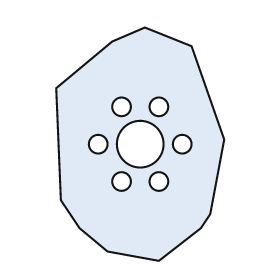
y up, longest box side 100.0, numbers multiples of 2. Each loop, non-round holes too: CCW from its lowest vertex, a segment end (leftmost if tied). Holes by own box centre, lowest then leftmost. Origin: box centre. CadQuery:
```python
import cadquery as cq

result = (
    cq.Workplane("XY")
    .moveTo(8.0, -50.0)
    .lineTo(26.0, -36.0)
    .lineTo(30.0, -30.0)
    .lineTo(36.0, 2.0)
    .lineTo(22.0, 42.0)
    .lineTo(2.0, 50.0)
    .lineTo(-12.0, 44.0)
    .lineTo(-36.0, 24.0)
    .lineTo(-34.0, -24.0)
    .lineTo(-26.0, -36.0)
    .lineTo(-14.0, -46.0)
    .close()
    .moveTo(-8.0, -16.0)
    .circle(4.0)
    .moveTo(8.0, -16.0)
    .circle(4.0)
    .moveTo(-18.0, 0.0)
    .circle(4.0)
    .moveTo(0.0, 0.0)
    .circle(10.0)
    .moveTo(18.0, 0.0)
    .circle(4.0)
    .moveTo(-8.0, 16.0)
    .circle(4.0)
    .moveTo(8.0, 16.0)
    .circle(4.0)
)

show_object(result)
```